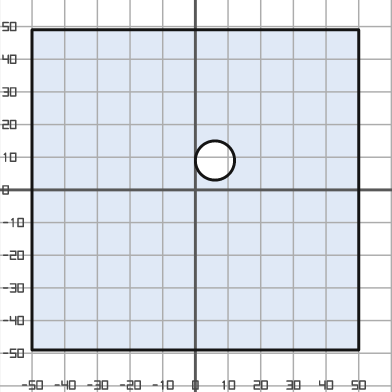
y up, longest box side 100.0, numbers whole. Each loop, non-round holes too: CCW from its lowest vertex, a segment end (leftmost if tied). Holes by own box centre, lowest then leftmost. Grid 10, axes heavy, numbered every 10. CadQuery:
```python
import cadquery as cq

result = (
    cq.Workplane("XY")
    .moveTo(-50.0, -49.0)
    .lineTo(50.0, -49.0)
    .lineTo(50.0, 49.0)
    .lineTo(-50.0, 49.0)
    .close()
    .moveTo(6.0, 9.0)
    .circle(6.0)
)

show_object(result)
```